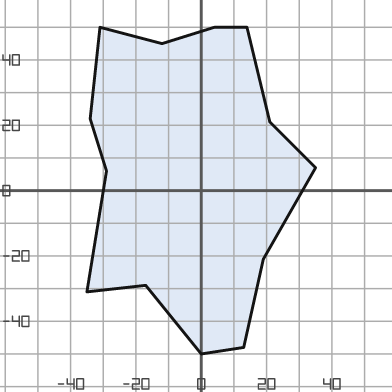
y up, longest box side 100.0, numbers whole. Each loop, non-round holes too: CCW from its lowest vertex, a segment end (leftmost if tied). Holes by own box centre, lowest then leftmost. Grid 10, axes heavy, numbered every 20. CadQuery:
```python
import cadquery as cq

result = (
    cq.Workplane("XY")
    .moveTo(0.0, -50.0)
    .lineTo(13.0, -48.0)
    .lineTo(19.0, -21.0)
    .lineTo(35.0, 7.0)
    .lineTo(21.0, 21.0)
    .lineTo(14.0, 50.0)
    .lineTo(4.0, 50.0)
    .lineTo(-12.0, 45.0)
    .lineTo(-31.0, 50.0)
    .lineTo(-34.0, 22.0)
    .lineTo(-29.0, 6.0)
    .lineTo(-35.0, -31.0)
    .lineTo(-17.0, -29.0)
    .close()
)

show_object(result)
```